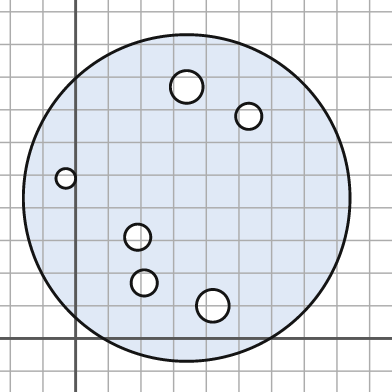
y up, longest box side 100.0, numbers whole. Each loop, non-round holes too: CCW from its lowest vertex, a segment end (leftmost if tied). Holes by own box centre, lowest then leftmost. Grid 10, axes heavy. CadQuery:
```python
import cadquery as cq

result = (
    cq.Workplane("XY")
    .moveTo(34.0, 43.0)
    .circle(50.0)
    .moveTo(42.0, 10.0)
    .circle(5.0)
    .moveTo(21.0, 17.0)
    .circle(4.0)
    .moveTo(19.0, 31.0)
    .circle(4.0)
    .moveTo(-3.0, 49.0)
    .circle(3.0)
    .moveTo(53.0, 68.0)
    .circle(4.0)
    .moveTo(34.0, 77.0)
    .circle(5.0)
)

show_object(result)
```